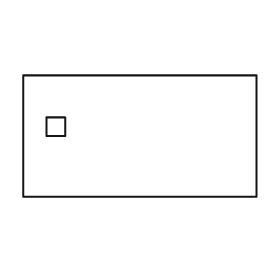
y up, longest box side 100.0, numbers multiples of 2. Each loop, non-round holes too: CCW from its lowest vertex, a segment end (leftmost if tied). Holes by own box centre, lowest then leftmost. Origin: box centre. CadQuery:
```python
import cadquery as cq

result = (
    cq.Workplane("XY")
    .moveTo(-50.0, -26.0)
    .lineTo(50.0, -26.0)
    .lineTo(50.0, 26.0)
    .lineTo(-50.0, 26.0)
    .close()
    .moveTo(-40.0, 0.0)
    .lineTo(-32.0, 0.0)
    .lineTo(-32.0, 8.0)
    .lineTo(-40.0, 8.0)
    .close()
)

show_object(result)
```